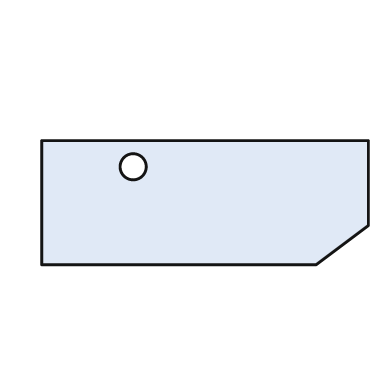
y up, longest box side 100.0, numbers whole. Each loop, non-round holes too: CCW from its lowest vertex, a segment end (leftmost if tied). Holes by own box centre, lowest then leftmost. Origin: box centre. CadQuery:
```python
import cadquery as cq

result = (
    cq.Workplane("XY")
    .moveTo(-50.0, -19.0)
    .lineTo(34.0, -19.0)
    .lineTo(50.0, -7.0)
    .lineTo(50.0, 19.0)
    .lineTo(-50.0, 19.0)
    .close()
    .moveTo(-22.0, 11.0)
    .circle(4.0)
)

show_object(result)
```